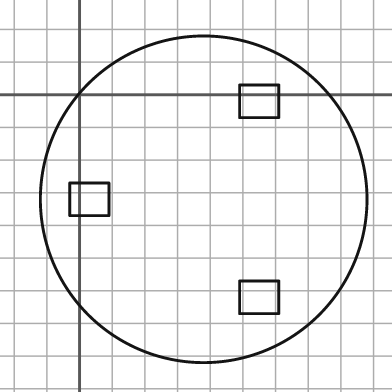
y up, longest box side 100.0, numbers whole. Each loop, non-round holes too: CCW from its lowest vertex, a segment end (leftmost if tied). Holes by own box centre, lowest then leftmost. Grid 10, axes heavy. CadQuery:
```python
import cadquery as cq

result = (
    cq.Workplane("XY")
    .moveTo(38.0, -32.0)
    .circle(50.0)
    .moveTo(49.0, -67.0)
    .lineTo(61.0, -67.0)
    .lineTo(61.0, -57.0)
    .lineTo(49.0, -57.0)
    .close()
    .moveTo(-3.0, -37.0)
    .lineTo(9.0, -37.0)
    .lineTo(9.0, -27.0)
    .lineTo(-3.0, -27.0)
    .close()
    .moveTo(49.0, -7.0)
    .lineTo(61.0, -7.0)
    .lineTo(61.0, 3.0)
    .lineTo(49.0, 3.0)
    .close()
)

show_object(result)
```